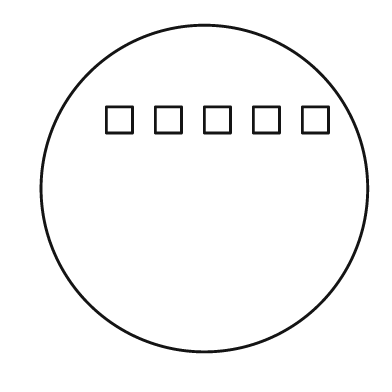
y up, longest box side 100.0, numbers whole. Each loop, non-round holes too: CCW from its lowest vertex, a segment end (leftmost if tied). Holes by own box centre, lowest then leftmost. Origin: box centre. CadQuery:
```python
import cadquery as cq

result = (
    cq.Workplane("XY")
    .moveTo(0.0, 0.0)
    .circle(50.0)
    .moveTo(-30.0, 17.0)
    .lineTo(-22.0, 17.0)
    .lineTo(-22.0, 25.0)
    .lineTo(-30.0, 25.0)
    .close()
    .moveTo(-15.0, 17.0)
    .lineTo(-7.0, 17.0)
    .lineTo(-7.0, 25.0)
    .lineTo(-15.0, 25.0)
    .close()
    .moveTo(0.0, 17.0)
    .lineTo(8.0, 17.0)
    .lineTo(8.0, 25.0)
    .lineTo(0.0, 25.0)
    .close()
    .moveTo(15.0, 17.0)
    .lineTo(23.0, 17.0)
    .lineTo(23.0, 25.0)
    .lineTo(15.0, 25.0)
    .close()
    .moveTo(30.0, 17.0)
    .lineTo(38.0, 17.0)
    .lineTo(38.0, 25.0)
    .lineTo(30.0, 25.0)
    .close()
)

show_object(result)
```